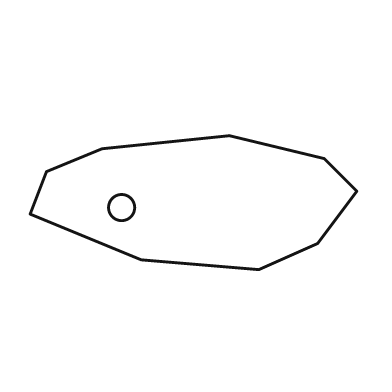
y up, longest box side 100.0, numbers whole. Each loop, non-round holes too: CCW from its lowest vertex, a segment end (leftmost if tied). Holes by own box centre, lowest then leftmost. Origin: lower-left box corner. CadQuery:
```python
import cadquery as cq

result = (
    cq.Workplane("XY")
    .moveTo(70.0, 0.0)
    .lineTo(88.0, 8.0)
    .lineTo(100.0, 24.0)
    .lineTo(90.0, 34.0)
    .lineTo(61.0, 41.0)
    .lineTo(22.0, 37.0)
    .lineTo(5.0, 30.0)
    .lineTo(0.0, 17.0)
    .lineTo(34.0, 3.0)
    .close()
    .moveTo(28.0, 19.0)
    .circle(4.0)
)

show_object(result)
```